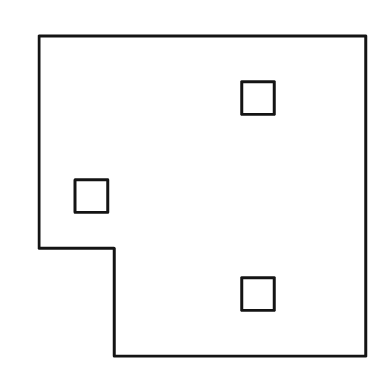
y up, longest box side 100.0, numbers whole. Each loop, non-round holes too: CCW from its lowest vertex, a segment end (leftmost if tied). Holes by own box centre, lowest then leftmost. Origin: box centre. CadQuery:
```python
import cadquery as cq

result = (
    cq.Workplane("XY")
    .moveTo(-27.0, -49.0)
    .lineTo(50.0, -49.0)
    .lineTo(50.0, 49.0)
    .lineTo(-50.0, 49.0)
    .lineTo(-50.0, -16.0)
    .lineTo(-27.0, -16.0)
    .close()
    .moveTo(12.0, -35.0)
    .lineTo(22.0, -35.0)
    .lineTo(22.0, -25.0)
    .lineTo(12.0, -25.0)
    .close()
    .moveTo(-39.0, -5.0)
    .lineTo(-29.0, -5.0)
    .lineTo(-29.0, 5.0)
    .lineTo(-39.0, 5.0)
    .close()
    .moveTo(12.0, 25.0)
    .lineTo(22.0, 25.0)
    .lineTo(22.0, 35.0)
    .lineTo(12.0, 35.0)
    .close()
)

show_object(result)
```